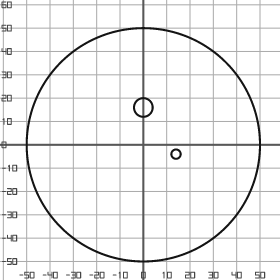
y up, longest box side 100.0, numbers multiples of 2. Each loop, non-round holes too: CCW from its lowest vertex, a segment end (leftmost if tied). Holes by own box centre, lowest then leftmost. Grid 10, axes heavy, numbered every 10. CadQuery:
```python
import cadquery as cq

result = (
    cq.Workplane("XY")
    .moveTo(0.0, 0.0)
    .circle(50.0)
    .moveTo(14.0, -4.0)
    .circle(2.0)
    .moveTo(0.0, 16.0)
    .circle(4.0)
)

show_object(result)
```